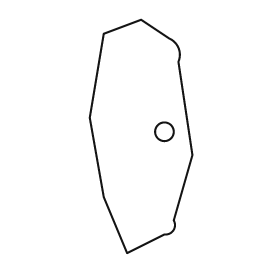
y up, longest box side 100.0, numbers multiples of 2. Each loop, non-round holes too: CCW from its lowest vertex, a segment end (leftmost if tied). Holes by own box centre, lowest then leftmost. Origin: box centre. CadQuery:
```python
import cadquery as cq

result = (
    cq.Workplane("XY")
    .moveTo(-6.0, -50.0)
    .lineTo(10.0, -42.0)
    .threePointArc((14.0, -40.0), (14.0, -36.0))
    .lineTo(22.0, -8.0)
    .lineTo(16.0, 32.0)
    .threePointArc((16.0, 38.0), (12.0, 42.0))
    .lineTo(0.0, 50.0)
    .lineTo(-16.0, 44.0)
    .lineTo(-22.0, 8.0)
    .lineTo(-16.0, -26.0)
    .close()
    .moveTo(10.0, 2.0)
    .circle(4.0)
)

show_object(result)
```